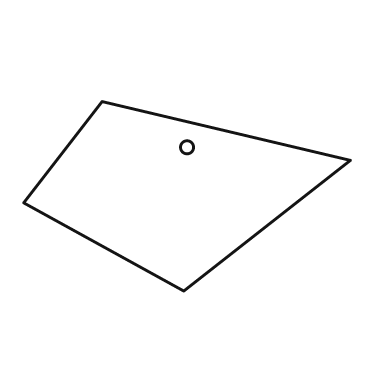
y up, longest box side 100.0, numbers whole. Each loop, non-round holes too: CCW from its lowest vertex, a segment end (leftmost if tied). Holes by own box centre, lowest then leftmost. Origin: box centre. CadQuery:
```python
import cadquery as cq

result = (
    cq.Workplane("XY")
    .moveTo(-1.0, -29.0)
    .lineTo(50.0, 11.0)
    .lineTo(-26.0, 29.0)
    .lineTo(-50.0, -2.0)
    .close()
    .moveTo(0.0, 15.0)
    .circle(2.0)
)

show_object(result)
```